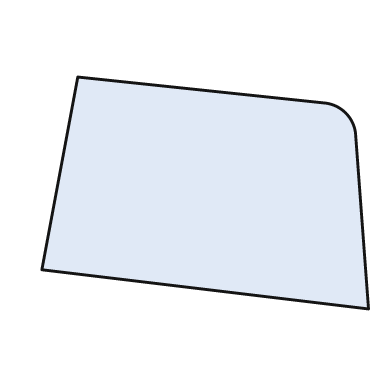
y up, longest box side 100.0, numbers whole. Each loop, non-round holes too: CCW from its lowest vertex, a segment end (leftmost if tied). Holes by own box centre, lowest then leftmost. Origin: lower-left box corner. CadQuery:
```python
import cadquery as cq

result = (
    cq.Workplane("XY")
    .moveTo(100.0, 0.0)
    .lineTo(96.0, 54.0)
    .threePointArc((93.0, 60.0), (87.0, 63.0))
    .lineTo(11.0, 71.0)
    .lineTo(0.0, 12.0)
    .close()
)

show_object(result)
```